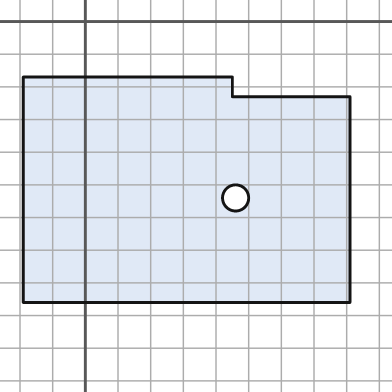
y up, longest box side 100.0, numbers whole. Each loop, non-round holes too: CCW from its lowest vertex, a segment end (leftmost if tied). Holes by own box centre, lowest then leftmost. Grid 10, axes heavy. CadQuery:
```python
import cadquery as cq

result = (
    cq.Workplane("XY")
    .moveTo(-19.0, -86.0)
    .lineTo(81.0, -86.0)
    .lineTo(81.0, -23.0)
    .lineTo(45.0, -23.0)
    .lineTo(45.0, -17.0)
    .lineTo(-19.0, -17.0)
    .close()
    .moveTo(46.0, -54.0)
    .circle(4.0)
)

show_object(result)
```